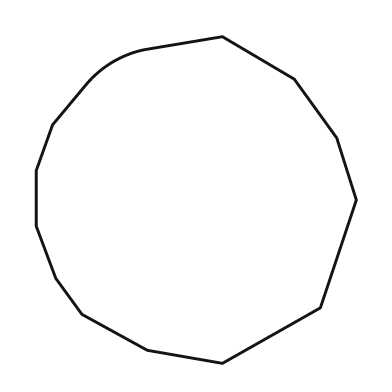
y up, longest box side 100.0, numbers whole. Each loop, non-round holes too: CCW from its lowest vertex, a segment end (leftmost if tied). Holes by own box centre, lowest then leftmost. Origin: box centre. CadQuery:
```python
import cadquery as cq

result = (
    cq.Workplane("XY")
    .moveTo(8.0, -50.0)
    .lineTo(38.0, -33.0)
    .lineTo(49.0, 0.0)
    .lineTo(43.0, 19.0)
    .lineTo(30.0, 37.0)
    .lineTo(8.0, 50.0)
    .lineTo(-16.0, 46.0)
    .threePointArc((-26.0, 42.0), (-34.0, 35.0))
    .lineTo(-44.0, 23.0)
    .lineTo(-49.0, 9.0)
    .lineTo(-49.0, -8.0)
    .lineTo(-43.0, -24.0)
    .lineTo(-35.0, -35.0)
    .lineTo(-15.0, -46.0)
    .close()
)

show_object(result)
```